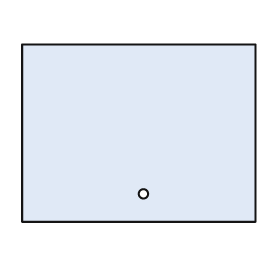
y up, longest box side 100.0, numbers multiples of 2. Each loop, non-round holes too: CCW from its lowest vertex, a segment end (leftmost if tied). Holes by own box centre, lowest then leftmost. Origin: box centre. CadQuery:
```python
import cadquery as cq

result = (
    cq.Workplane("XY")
    .moveTo(-50.0, -38.0)
    .lineTo(50.0, -38.0)
    .lineTo(50.0, 38.0)
    .lineTo(-50.0, 38.0)
    .close()
    .moveTo(2.0, -26.0)
    .circle(2.0)
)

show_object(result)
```